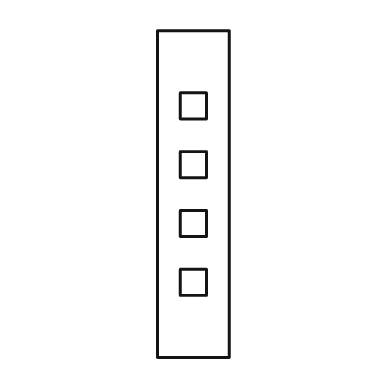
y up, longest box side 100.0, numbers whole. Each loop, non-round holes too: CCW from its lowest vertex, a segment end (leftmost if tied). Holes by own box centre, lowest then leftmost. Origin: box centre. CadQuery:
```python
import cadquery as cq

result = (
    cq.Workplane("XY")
    .moveTo(-11.0, -50.0)
    .lineTo(11.0, -50.0)
    .lineTo(11.0, 50.0)
    .lineTo(-11.0, 50.0)
    .close()
    .moveTo(-4.0, -31.0)
    .lineTo(4.0, -31.0)
    .lineTo(4.0, -23.0)
    .lineTo(-4.0, -23.0)
    .close()
    .moveTo(-4.0, -13.0)
    .lineTo(4.0, -13.0)
    .lineTo(4.0, -5.0)
    .lineTo(-4.0, -5.0)
    .close()
    .moveTo(-4.0, 5.0)
    .lineTo(4.0, 5.0)
    .lineTo(4.0, 13.0)
    .lineTo(-4.0, 13.0)
    .close()
    .moveTo(-4.0, 23.0)
    .lineTo(4.0, 23.0)
    .lineTo(4.0, 31.0)
    .lineTo(-4.0, 31.0)
    .close()
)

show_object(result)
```